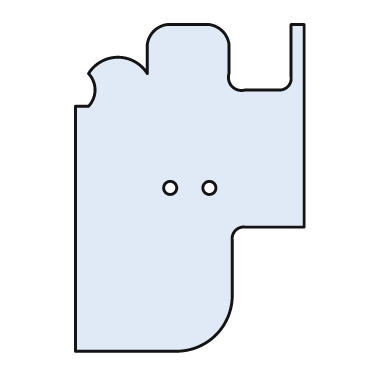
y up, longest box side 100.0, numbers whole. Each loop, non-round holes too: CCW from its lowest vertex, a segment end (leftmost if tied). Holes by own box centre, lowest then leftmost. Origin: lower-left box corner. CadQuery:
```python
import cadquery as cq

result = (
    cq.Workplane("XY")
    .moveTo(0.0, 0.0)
    .lineTo(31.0, 0.0)
    .threePointArc((43.0, 5.0), (48.0, 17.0))
    .lineTo(48.0, 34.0)
    .threePointArc((49.0, 37.0), (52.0, 38.0))
    .lineTo(70.0, 38.0)
    .lineTo(70.0, 100.0)
    .lineTo(66.0, 100.0)
    .lineTo(66.0, 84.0)
    .threePointArc((65.0, 81.0), (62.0, 80.0))
    .lineTo(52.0, 80.0)
    .threePointArc((48.0, 81.0), (47.0, 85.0))
    .lineTo(47.0, 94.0)
    .threePointArc((45.0, 98.0), (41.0, 100.0))
    .lineTo(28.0, 100.0)
    .threePointArc((24.0, 98.0), (22.0, 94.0))
    .lineTo(22.0, 85.0)
    .threePointArc((13.0, 90.0), (4.0, 85.0))
    .threePointArc((6.0, 80.0), (4.0, 75.0))
    .lineTo(0.0, 75.0)
    .close()
    .moveTo(29.0, 50.0)
    .circle(2.0)
    .moveTo(41.0, 50.0)
    .circle(2.0)
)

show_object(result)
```